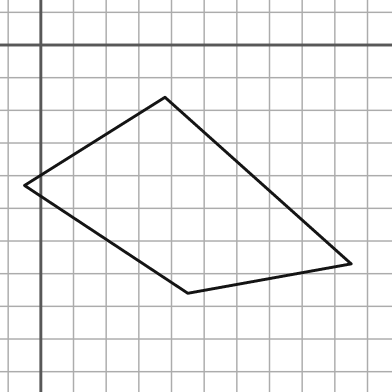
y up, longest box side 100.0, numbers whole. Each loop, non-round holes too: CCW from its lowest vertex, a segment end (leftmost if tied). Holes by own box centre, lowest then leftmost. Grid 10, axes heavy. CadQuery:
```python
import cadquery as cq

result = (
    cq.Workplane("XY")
    .moveTo(45.0, -76.0)
    .lineTo(95.0, -67.0)
    .lineTo(38.0, -16.0)
    .lineTo(-5.0, -43.0)
    .close()
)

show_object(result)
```